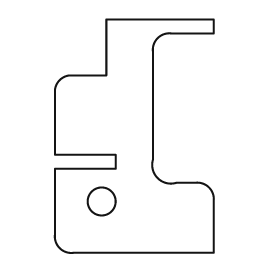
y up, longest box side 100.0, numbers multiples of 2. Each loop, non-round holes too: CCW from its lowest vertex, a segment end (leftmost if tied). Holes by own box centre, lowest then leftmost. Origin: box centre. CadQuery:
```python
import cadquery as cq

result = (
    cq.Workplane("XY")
    .moveTo(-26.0, -50.0)
    .lineTo(34.0, -50.0)
    .lineTo(34.0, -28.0)
    .threePointArc((32.0, -22.0), (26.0, -20.0))
    .lineTo(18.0, -20.0)
    .threePointArc((10.0, -18.0), (8.0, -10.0))
    .lineTo(8.0, 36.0)
    .threePointArc((10.0, 42.0), (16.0, 44.0))
    .lineTo(34.0, 44.0)
    .lineTo(34.0, 50.0)
    .lineTo(-12.0, 50.0)
    .lineTo(-12.0, 26.0)
    .lineTo(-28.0, 26.0)
    .threePointArc((-32.0, 24.0), (-34.0, 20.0))
    .lineTo(-34.0, -8.0)
    .lineTo(-8.0, -8.0)
    .lineTo(-8.0, -14.0)
    .lineTo(-34.0, -14.0)
    .lineTo(-34.0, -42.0)
    .threePointArc((-32.0, -48.0), (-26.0, -50.0))
    .close()
    .moveTo(-14.0, -28.0)
    .circle(6.0)
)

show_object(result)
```